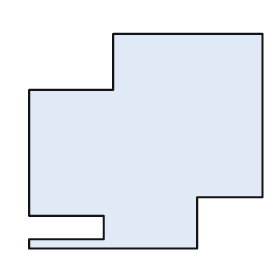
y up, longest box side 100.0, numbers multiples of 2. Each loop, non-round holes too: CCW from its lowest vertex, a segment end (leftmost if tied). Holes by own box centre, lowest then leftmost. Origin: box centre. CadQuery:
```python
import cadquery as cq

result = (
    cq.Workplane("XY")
    .moveTo(-50.0, -46.0)
    .lineTo(22.0, -46.0)
    .lineTo(22.0, -24.0)
    .lineTo(50.0, -24.0)
    .lineTo(50.0, 46.0)
    .lineTo(-14.0, 46.0)
    .lineTo(-14.0, 22.0)
    .lineTo(-50.0, 22.0)
    .lineTo(-50.0, -32.0)
    .lineTo(-18.0, -32.0)
    .lineTo(-18.0, -42.0)
    .lineTo(-50.0, -42.0)
    .close()
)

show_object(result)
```